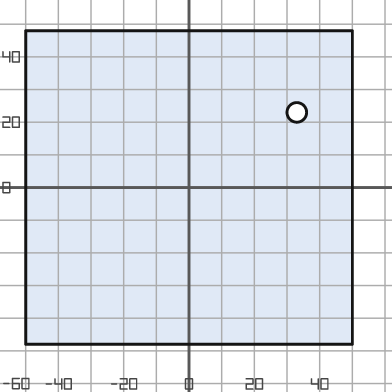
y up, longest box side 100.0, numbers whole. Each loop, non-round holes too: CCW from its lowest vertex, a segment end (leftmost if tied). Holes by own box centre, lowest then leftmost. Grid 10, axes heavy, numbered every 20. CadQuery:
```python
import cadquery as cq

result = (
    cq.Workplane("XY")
    .moveTo(-50.0, -48.0)
    .lineTo(50.0, -48.0)
    .lineTo(50.0, 48.0)
    .lineTo(-50.0, 48.0)
    .close()
    .moveTo(33.0, 23.0)
    .circle(3.0)
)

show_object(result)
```